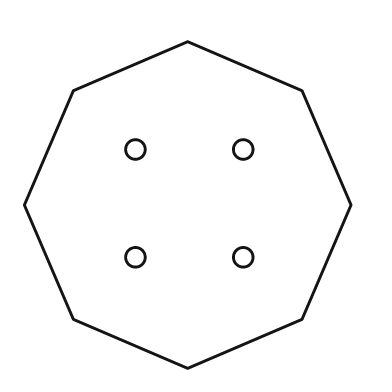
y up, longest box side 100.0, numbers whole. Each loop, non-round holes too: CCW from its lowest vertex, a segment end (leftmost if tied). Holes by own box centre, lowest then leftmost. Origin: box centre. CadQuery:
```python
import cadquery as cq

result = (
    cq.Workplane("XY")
    .moveTo(0.0, -50.0)
    .lineTo(35.0, -35.0)
    .lineTo(50.0, 0.0)
    .lineTo(35.0, 35.0)
    .lineTo(0.0, 50.0)
    .lineTo(-35.0, 35.0)
    .lineTo(-50.0, 0.0)
    .lineTo(-35.0, -35.0)
    .close()
    .moveTo(-16.0, -16.0)
    .circle(3.0)
    .moveTo(17.0, -16.0)
    .circle(3.0)
    .moveTo(-16.0, 17.0)
    .circle(3.0)
    .moveTo(17.0, 17.0)
    .circle(3.0)
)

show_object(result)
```